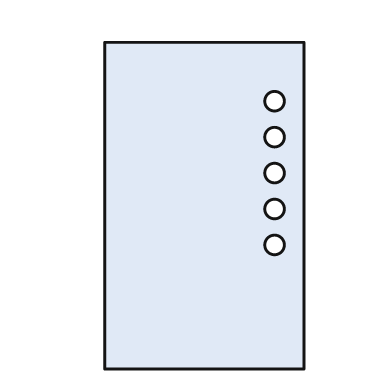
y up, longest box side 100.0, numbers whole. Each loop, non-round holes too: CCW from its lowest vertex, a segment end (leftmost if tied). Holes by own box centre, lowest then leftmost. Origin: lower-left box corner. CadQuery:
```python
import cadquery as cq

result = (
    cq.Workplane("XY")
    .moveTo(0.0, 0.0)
    .lineTo(61.0, 0.0)
    .lineTo(61.0, 100.0)
    .lineTo(0.0, 100.0)
    .close()
    .moveTo(52.0, 38.0)
    .circle(3.0)
    .moveTo(52.0, 49.0)
    .circle(3.0)
    .moveTo(52.0, 60.0)
    .circle(3.0)
    .moveTo(52.0, 71.0)
    .circle(3.0)
    .moveTo(52.0, 82.0)
    .circle(3.0)
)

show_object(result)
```